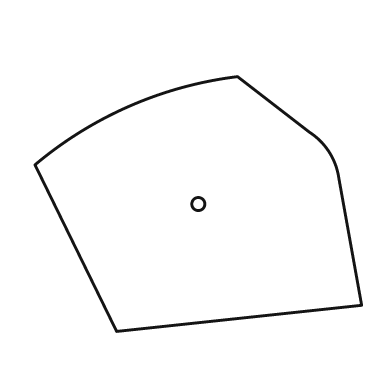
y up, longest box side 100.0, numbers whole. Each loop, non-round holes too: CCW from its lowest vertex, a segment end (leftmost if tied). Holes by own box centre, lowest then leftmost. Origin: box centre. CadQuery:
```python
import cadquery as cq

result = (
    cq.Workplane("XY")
    .moveTo(-25.0, -39.0)
    .lineTo(50.0, -31.0)
    .lineTo(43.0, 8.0)
    .threePointArc((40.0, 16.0), (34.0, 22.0))
    .lineTo(12.0, 39.0)
    .threePointArc((-21.0, 30.0), (-50.0, 12.0))
    .close()
    .moveTo(0.0, 0.0)
    .circle(2.0)
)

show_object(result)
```